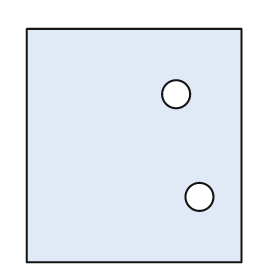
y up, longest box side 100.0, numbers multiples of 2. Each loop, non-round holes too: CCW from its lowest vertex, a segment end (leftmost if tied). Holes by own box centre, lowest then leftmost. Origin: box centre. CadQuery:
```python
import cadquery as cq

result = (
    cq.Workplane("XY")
    .moveTo(-46.0, -50.0)
    .lineTo(46.0, -50.0)
    .lineTo(46.0, 50.0)
    .lineTo(-46.0, 50.0)
    .close()
    .moveTo(28.0, -22.0)
    .circle(6.0)
    .moveTo(18.0, 22.0)
    .circle(6.0)
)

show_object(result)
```